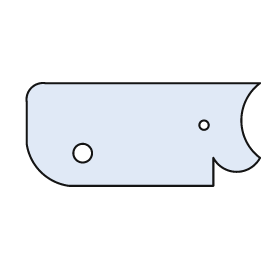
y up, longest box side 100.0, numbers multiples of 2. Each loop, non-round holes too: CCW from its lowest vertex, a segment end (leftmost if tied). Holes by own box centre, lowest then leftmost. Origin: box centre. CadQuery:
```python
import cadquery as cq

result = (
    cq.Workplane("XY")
    .moveTo(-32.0, -22.0)
    .lineTo(30.0, -22.0)
    .lineTo(30.0, -10.0)
    .threePointArc((40.0, -16.0), (50.0, -10.0))
    .threePointArc((42.0, 6.0), (50.0, 22.0))
    .lineTo(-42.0, 22.0)
    .threePointArc((-48.0, 20.0), (-50.0, 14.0))
    .lineTo(-50.0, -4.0)
    .threePointArc((-44.0, -16.0), (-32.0, -22.0))
    .close()
    .moveTo(-26.0, -8.0)
    .circle(4.0)
    .moveTo(26.0, 4.0)
    .circle(2.0)
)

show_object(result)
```